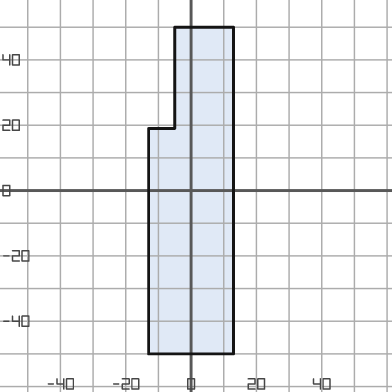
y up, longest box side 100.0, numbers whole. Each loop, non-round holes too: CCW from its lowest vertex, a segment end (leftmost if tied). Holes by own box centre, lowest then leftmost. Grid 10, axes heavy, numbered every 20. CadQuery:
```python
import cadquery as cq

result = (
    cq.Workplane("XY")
    .moveTo(-13.0, -50.0)
    .lineTo(13.0, -50.0)
    .lineTo(13.0, 50.0)
    .lineTo(-5.0, 50.0)
    .lineTo(-5.0, 19.0)
    .lineTo(-13.0, 19.0)
    .close()
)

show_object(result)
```